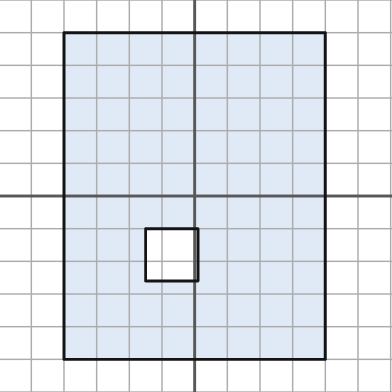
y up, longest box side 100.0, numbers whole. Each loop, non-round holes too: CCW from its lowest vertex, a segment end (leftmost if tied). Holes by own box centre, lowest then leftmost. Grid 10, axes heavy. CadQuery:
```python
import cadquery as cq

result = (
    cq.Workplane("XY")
    .moveTo(-40.0, -50.0)
    .lineTo(40.0, -50.0)
    .lineTo(40.0, 50.0)
    .lineTo(-40.0, 50.0)
    .close()
    .moveTo(-15.0, -26.0)
    .lineTo(1.0, -26.0)
    .lineTo(1.0, -10.0)
    .lineTo(-15.0, -10.0)
    .close()
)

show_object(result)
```